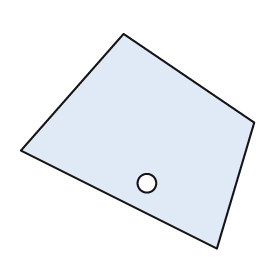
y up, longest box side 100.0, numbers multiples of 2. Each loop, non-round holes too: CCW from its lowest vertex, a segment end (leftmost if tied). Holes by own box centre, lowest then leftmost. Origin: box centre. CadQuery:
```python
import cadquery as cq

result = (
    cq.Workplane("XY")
    .moveTo(34.0, -46.0)
    .lineTo(50.0, 8.0)
    .lineTo(-6.0, 46.0)
    .lineTo(-50.0, -4.0)
    .close()
    .moveTo(4.0, -18.0)
    .circle(4.0)
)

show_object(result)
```